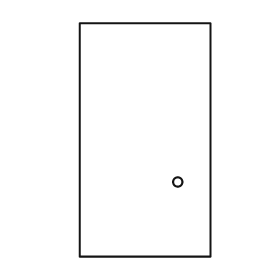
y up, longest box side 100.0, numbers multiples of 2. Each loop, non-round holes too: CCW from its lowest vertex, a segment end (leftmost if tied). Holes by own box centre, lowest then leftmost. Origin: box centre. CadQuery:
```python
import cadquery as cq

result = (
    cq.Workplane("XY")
    .moveTo(-28.0, -50.0)
    .lineTo(28.0, -50.0)
    .lineTo(28.0, 50.0)
    .lineTo(-28.0, 50.0)
    .close()
    .moveTo(14.0, -18.0)
    .circle(2.0)
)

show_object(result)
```